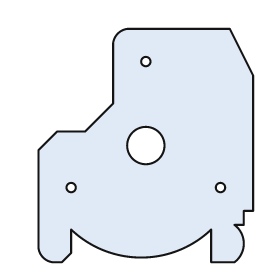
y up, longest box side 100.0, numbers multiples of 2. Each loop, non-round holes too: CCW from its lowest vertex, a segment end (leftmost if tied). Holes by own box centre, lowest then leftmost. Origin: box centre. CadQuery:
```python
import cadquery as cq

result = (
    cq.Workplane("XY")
    .moveTo(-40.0, -50.0)
    .lineTo(-36.0, -50.0)
    .lineTo(-32.0, -46.0)
    .lineTo(-32.0, -36.0)
    .threePointArc((-2.0, -48.0), (28.0, -36.0))
    .lineTo(28.0, -50.0)
    .lineTo(38.0, -50.0)
    .threePointArc((42.0, -42.0), (38.0, -34.0))
    .lineTo(42.0, -34.0)
    .lineTo(42.0, -28.0)
    .lineTo(46.0, -28.0)
    .lineTo(46.0, 30.0)
    .lineTo(36.0, 50.0)
    .lineTo(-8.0, 50.0)
    .threePointArc((-12.0, 48.0), (-14.0, 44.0))
    .lineTo(-14.0, 18.0)
    .lineTo(-26.0, 6.0)
    .lineTo(-38.0, 6.0)
    .lineTo(-46.0, -2.0)
    .lineTo(-46.0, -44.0)
    .threePointArc((-44.0, -48.0), (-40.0, -50.0))
    .close()
    .moveTo(-32.0, -18.0)
    .circle(2.0)
    .moveTo(32.0, -18.0)
    .circle(2.0)
    .moveTo(0.0, 0.0)
    .circle(8.0)
    .moveTo(0.0, 36.0)
    .circle(2.0)
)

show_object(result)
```